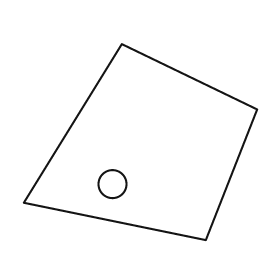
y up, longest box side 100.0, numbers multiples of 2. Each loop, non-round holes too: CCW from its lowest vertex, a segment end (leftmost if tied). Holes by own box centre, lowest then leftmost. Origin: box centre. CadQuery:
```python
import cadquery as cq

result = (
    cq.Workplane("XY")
    .moveTo(28.0, -42.0)
    .lineTo(50.0, 14.0)
    .lineTo(-8.0, 42.0)
    .lineTo(-50.0, -26.0)
    .close()
    .moveTo(-12.0, -18.0)
    .circle(6.0)
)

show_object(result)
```